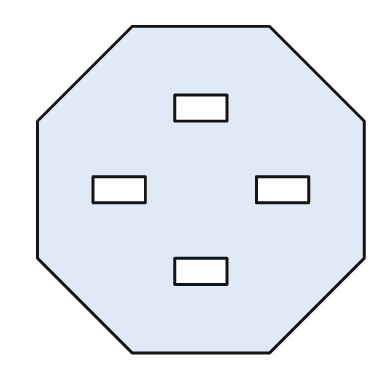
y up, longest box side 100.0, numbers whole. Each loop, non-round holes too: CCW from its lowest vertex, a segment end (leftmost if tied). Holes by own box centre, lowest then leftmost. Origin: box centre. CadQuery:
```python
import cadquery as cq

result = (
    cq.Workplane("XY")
    .moveTo(-21.0, -50.0)
    .lineTo(21.0, -50.0)
    .lineTo(50.0, -21.0)
    .lineTo(50.0, 21.0)
    .lineTo(21.0, 50.0)
    .lineTo(-21.0, 50.0)
    .lineTo(-50.0, 21.0)
    .lineTo(-50.0, -21.0)
    .close()
    .moveTo(-8.0, -29.0)
    .lineTo(8.0, -29.0)
    .lineTo(8.0, -21.0)
    .lineTo(-8.0, -21.0)
    .close()
    .moveTo(-33.0, -4.0)
    .lineTo(-17.0, -4.0)
    .lineTo(-17.0, 4.0)
    .lineTo(-33.0, 4.0)
    .close()
    .moveTo(17.0, -4.0)
    .lineTo(33.0, -4.0)
    .lineTo(33.0, 4.0)
    .lineTo(17.0, 4.0)
    .close()
    .moveTo(-8.0, 21.0)
    .lineTo(8.0, 21.0)
    .lineTo(8.0, 29.0)
    .lineTo(-8.0, 29.0)
    .close()
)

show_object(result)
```